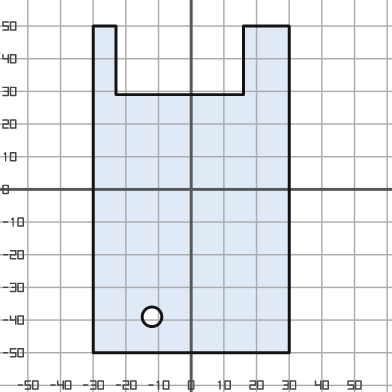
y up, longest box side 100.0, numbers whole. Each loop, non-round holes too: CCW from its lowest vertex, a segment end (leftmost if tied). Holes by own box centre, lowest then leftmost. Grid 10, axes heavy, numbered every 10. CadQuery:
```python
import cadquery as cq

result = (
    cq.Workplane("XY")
    .moveTo(-30.0, -50.0)
    .lineTo(30.0, -50.0)
    .lineTo(30.0, 50.0)
    .lineTo(16.0, 50.0)
    .lineTo(16.0, 29.0)
    .lineTo(-23.0, 29.0)
    .lineTo(-23.0, 50.0)
    .lineTo(-30.0, 50.0)
    .close()
    .moveTo(-12.0, -39.0)
    .circle(3.0)
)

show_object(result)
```